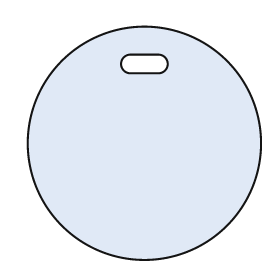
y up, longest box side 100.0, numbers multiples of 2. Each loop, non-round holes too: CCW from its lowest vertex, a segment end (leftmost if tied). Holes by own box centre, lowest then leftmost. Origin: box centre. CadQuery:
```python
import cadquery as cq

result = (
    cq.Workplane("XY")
    .moveTo(0.0, 0.0)
    .circle(50.0)
    .moveTo(-6.0, 30.0)
    .lineTo(6.0, 30.0)
    .threePointArc((10.0, 34.0), (6.0, 38.0))
    .lineTo(-6.0, 38.0)
    .threePointArc((-10.0, 34.0), (-6.0, 30.0))
    .close()
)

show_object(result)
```